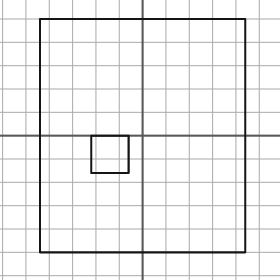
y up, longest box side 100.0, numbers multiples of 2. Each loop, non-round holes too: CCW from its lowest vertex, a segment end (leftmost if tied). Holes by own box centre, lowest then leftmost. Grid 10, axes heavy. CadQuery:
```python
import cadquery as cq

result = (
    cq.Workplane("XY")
    .moveTo(-44.0, -50.0)
    .lineTo(44.0, -50.0)
    .lineTo(44.0, 50.0)
    .lineTo(-44.0, 50.0)
    .close()
    .moveTo(-22.0, -16.0)
    .lineTo(-6.0, -16.0)
    .lineTo(-6.0, 0.0)
    .lineTo(-22.0, 0.0)
    .close()
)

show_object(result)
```